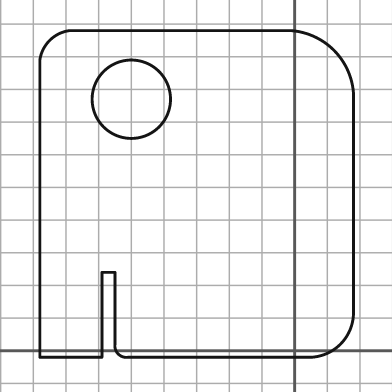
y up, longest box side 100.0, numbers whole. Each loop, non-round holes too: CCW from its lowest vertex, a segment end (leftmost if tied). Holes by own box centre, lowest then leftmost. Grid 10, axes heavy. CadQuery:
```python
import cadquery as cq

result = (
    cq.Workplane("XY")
    .moveTo(-78.0, -2.0)
    .lineTo(-59.0, -2.0)
    .lineTo(-59.0, 24.0)
    .lineTo(-55.0, 24.0)
    .lineTo(-55.0, 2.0)
    .threePointArc((-54.0, -1.0), (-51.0, -2.0))
    .lineTo(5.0, -2.0)
    .threePointArc((14.0, 2.0), (18.0, 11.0))
    .lineTo(18.0, 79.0)
    .threePointArc((12.0, 92.0), (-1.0, 98.0))
    .lineTo(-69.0, 98.0)
    .threePointArc((-75.0, 95.0), (-78.0, 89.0))
    .close()
    .moveTo(-50.0, 77.0)
    .circle(12.0)
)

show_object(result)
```